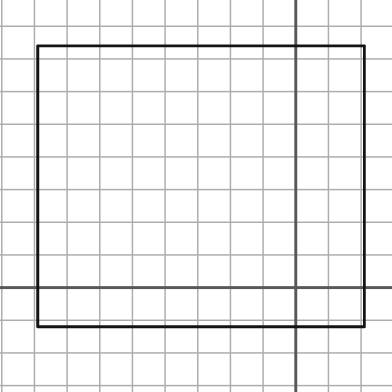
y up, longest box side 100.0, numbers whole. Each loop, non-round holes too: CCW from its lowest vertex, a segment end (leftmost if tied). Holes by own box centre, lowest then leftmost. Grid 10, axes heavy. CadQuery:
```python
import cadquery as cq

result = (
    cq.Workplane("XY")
    .moveTo(-79.0, -12.0)
    .lineTo(21.0, -12.0)
    .lineTo(21.0, 74.0)
    .lineTo(-79.0, 74.0)
    .close()
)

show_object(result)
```